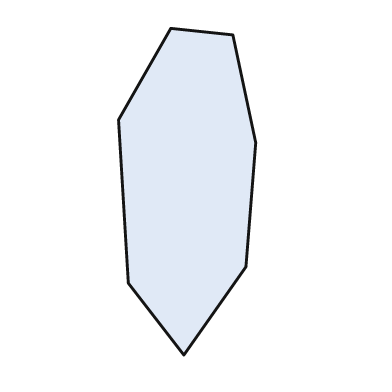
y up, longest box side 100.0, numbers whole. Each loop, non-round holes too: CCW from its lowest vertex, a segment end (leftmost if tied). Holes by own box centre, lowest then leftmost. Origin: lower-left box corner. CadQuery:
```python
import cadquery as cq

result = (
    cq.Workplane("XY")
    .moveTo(20.0, 0.0)
    .lineTo(39.0, 27.0)
    .lineTo(42.0, 65.0)
    .lineTo(35.0, 98.0)
    .lineTo(16.0, 100.0)
    .lineTo(0.0, 72.0)
    .lineTo(3.0, 22.0)
    .close()
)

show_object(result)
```